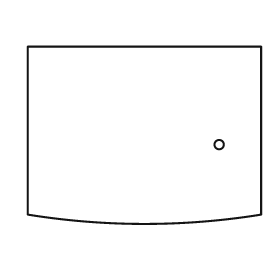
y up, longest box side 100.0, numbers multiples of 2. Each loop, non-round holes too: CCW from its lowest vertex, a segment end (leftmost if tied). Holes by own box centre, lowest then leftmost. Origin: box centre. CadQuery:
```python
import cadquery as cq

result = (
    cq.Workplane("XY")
    .moveTo(-50.0, -34.0)
    .threePointArc((0.0, -38.0), (50.0, -34.0))
    .lineTo(50.0, 38.0)
    .lineTo(-50.0, 38.0)
    .close()
    .moveTo(32.0, -4.0)
    .circle(2.0)
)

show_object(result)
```